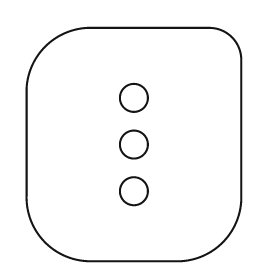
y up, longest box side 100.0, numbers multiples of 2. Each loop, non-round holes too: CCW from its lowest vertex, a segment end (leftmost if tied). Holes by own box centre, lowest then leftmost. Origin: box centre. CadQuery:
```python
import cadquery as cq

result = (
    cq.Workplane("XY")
    .moveTo(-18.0, -50.0)
    .lineTo(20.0, -50.0)
    .threePointArc((38.0, -42.0), (46.0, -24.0))
    .lineTo(46.0, 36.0)
    .threePointArc((42.0, 46.0), (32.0, 50.0))
    .lineTo(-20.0, 50.0)
    .threePointArc((-38.0, 42.0), (-46.0, 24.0))
    .lineTo(-46.0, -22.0)
    .threePointArc((-38.0, -42.0), (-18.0, -50.0))
    .close()
    .moveTo(0.0, -20.0)
    .circle(6.0)
    .moveTo(0.0, 0.0)
    .circle(6.0)
    .moveTo(0.0, 20.0)
    .circle(6.0)
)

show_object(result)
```